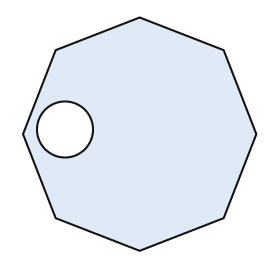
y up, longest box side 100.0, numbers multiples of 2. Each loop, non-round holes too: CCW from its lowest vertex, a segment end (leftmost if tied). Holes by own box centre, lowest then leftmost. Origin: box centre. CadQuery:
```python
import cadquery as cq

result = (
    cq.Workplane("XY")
    .moveTo(0.0, -50.0)
    .lineTo(36.0, -36.0)
    .lineTo(50.0, 0.0)
    .lineTo(36.0, 36.0)
    .lineTo(0.0, 50.0)
    .lineTo(-36.0, 36.0)
    .lineTo(-50.0, 0.0)
    .lineTo(-36.0, -36.0)
    .close()
    .moveTo(-32.0, 2.0)
    .circle(12.0)
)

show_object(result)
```